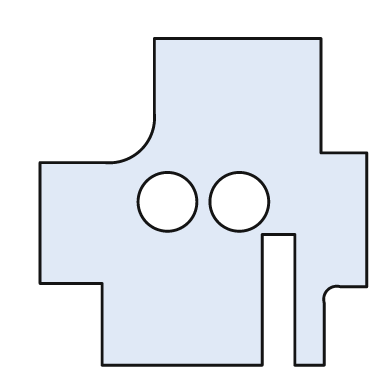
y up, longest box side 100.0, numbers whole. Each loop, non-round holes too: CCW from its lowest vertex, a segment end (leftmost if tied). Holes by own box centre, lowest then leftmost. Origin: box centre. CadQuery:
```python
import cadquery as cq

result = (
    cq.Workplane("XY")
    .moveTo(-31.0, -50.0)
    .lineTo(18.0, -50.0)
    .lineTo(18.0, -10.0)
    .lineTo(28.0, -10.0)
    .lineTo(28.0, -50.0)
    .lineTo(37.0, -50.0)
    .lineTo(37.0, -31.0)
    .threePointArc((38.0, -27.0), (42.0, -26.0))
    .lineTo(50.0, -26.0)
    .lineTo(50.0, 15.0)
    .lineTo(36.0, 15.0)
    .lineTo(36.0, 50.0)
    .lineTo(-15.0, 50.0)
    .lineTo(-15.0, 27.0)
    .threePointArc((-19.0, 16.0), (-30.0, 12.0))
    .lineTo(-50.0, 12.0)
    .lineTo(-50.0, -25.0)
    .lineTo(-31.0, -25.0)
    .close()
    .moveTo(-11.0, 0.0)
    .circle(9.0)
    .moveTo(11.0, 0.0)
    .circle(9.0)
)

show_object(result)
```